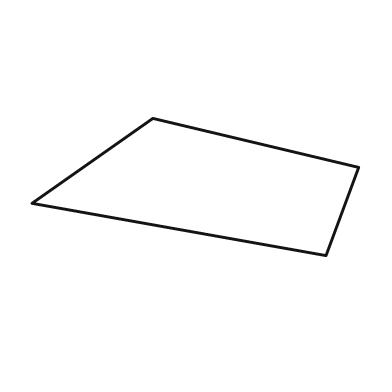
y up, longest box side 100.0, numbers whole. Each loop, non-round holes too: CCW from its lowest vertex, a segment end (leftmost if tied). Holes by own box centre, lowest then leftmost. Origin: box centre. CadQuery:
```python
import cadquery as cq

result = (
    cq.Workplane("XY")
    .moveTo(40.0, -21.0)
    .lineTo(50.0, 6.0)
    .lineTo(-13.0, 21.0)
    .lineTo(-50.0, -5.0)
    .close()
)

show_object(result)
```